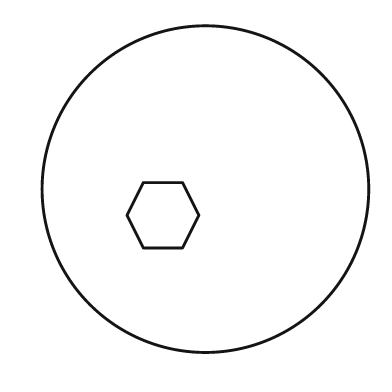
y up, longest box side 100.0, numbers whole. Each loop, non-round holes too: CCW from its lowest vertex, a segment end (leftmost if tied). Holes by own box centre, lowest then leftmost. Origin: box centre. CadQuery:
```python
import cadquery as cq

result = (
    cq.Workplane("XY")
    .moveTo(0.0, 0.0)
    .circle(50.0)
    .moveTo(-19.0, -18.0)
    .lineTo(-7.0, -18.0)
    .lineTo(-2.0, -8.0)
    .lineTo(-7.0, 2.0)
    .lineTo(-19.0, 2.0)
    .lineTo(-24.0, -8.0)
    .close()
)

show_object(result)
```